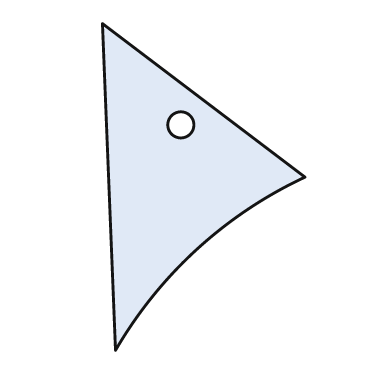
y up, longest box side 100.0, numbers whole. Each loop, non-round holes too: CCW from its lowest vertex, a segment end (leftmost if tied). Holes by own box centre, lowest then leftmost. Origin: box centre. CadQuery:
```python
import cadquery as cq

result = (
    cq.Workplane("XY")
    .moveTo(-27.0, -50.0)
    .threePointArc((-2.0, -19.0), (31.0, 3.0))
    .lineTo(-31.0, 50.0)
    .close()
    .moveTo(-7.0, 19.0)
    .circle(4.0)
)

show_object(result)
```